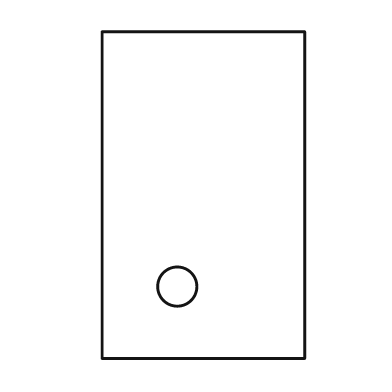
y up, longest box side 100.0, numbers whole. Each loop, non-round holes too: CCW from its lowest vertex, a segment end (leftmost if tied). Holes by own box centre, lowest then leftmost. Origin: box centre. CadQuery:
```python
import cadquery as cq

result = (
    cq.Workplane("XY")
    .moveTo(-31.0, -50.0)
    .lineTo(31.0, -50.0)
    .lineTo(31.0, 50.0)
    .lineTo(-31.0, 50.0)
    .close()
    .moveTo(-8.0, -28.0)
    .circle(6.0)
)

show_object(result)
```